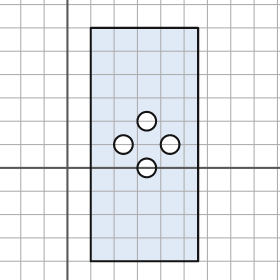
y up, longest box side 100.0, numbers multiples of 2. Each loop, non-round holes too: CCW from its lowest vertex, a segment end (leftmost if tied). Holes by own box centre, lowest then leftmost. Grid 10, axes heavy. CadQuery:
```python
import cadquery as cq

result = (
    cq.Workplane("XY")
    .moveTo(10.0, -40.0)
    .lineTo(56.0, -40.0)
    .lineTo(56.0, 60.0)
    .lineTo(10.0, 60.0)
    .close()
    .moveTo(34.0, 0.0)
    .circle(4.0)
    .moveTo(24.0, 10.0)
    .circle(4.0)
    .moveTo(44.0, 10.0)
    .circle(4.0)
    .moveTo(34.0, 20.0)
    .circle(4.0)
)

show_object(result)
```